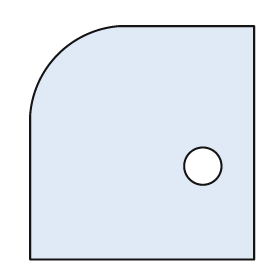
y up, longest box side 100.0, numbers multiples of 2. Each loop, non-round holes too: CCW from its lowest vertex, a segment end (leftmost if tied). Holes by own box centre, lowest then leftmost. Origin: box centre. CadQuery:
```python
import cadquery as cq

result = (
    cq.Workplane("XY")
    .moveTo(-48.0, -50.0)
    .lineTo(48.0, -50.0)
    .lineTo(48.0, 50.0)
    .lineTo(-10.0, 50.0)
    .threePointArc((-36.0, 38.0), (-48.0, 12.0))
    .close()
    .moveTo(26.0, -10.0)
    .circle(8.0)
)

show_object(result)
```